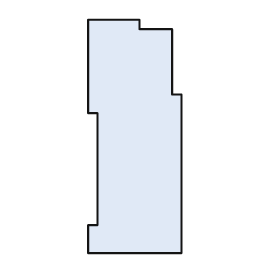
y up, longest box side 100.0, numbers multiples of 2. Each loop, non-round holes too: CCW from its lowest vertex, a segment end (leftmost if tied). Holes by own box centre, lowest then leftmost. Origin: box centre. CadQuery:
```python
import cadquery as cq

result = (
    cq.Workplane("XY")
    .moveTo(-20.0, -50.0)
    .lineTo(20.0, -50.0)
    .lineTo(20.0, 18.0)
    .lineTo(16.0, 18.0)
    .lineTo(16.0, 46.0)
    .lineTo(2.0, 46.0)
    .lineTo(2.0, 50.0)
    .lineTo(-20.0, 50.0)
    .lineTo(-20.0, 10.0)
    .lineTo(-16.0, 10.0)
    .lineTo(-16.0, -38.0)
    .lineTo(-20.0, -38.0)
    .close()
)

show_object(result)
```